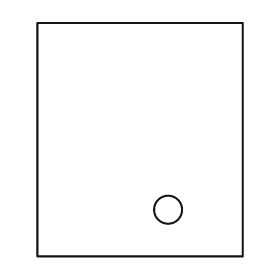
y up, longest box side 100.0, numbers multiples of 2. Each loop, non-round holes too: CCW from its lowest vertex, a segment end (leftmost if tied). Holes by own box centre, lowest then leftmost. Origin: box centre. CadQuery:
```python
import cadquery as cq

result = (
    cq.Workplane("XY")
    .moveTo(-44.0, -50.0)
    .lineTo(44.0, -50.0)
    .lineTo(44.0, 50.0)
    .lineTo(-44.0, 50.0)
    .close()
    .moveTo(12.0, -30.0)
    .circle(6.0)
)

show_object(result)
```